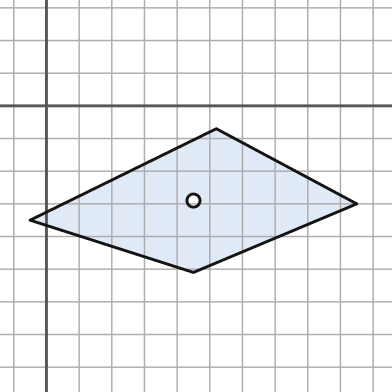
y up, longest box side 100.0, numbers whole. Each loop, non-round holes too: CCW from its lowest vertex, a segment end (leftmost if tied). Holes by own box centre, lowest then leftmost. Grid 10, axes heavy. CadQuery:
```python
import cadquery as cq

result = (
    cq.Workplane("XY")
    .moveTo(45.0, -51.0)
    .lineTo(95.0, -30.0)
    .lineTo(52.0, -7.0)
    .lineTo(-5.0, -35.0)
    .close()
    .moveTo(45.0, -29.0)
    .circle(2.0)
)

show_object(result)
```